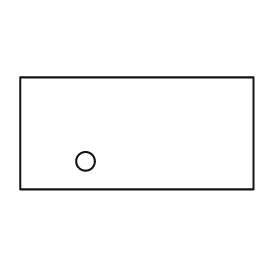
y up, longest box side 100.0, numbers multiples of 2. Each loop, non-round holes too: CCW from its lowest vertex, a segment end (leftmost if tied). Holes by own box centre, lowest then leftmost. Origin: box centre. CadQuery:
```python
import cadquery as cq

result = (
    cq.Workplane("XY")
    .moveTo(-50.0, -24.0)
    .lineTo(50.0, -24.0)
    .lineTo(50.0, 24.0)
    .lineTo(-50.0, 24.0)
    .close()
    .moveTo(-22.0, -12.0)
    .circle(4.0)
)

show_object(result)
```